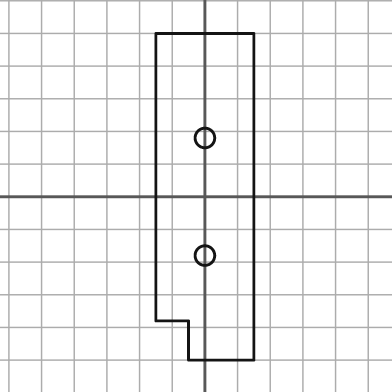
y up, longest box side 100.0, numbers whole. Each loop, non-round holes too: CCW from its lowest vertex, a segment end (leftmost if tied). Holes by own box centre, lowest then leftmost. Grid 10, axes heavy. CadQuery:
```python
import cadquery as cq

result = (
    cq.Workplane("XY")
    .moveTo(-5.0, -50.0)
    .lineTo(15.0, -50.0)
    .lineTo(15.0, 50.0)
    .lineTo(-15.0, 50.0)
    .lineTo(-15.0, -38.0)
    .lineTo(-5.0, -38.0)
    .close()
    .moveTo(0.0, -18.0)
    .circle(3.0)
    .moveTo(0.0, 18.0)
    .circle(3.0)
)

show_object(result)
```